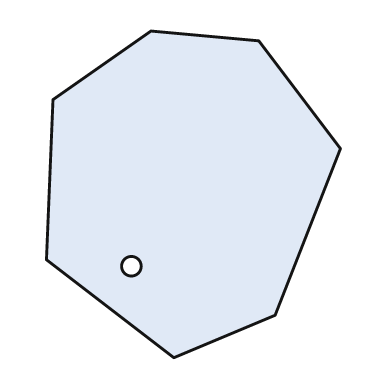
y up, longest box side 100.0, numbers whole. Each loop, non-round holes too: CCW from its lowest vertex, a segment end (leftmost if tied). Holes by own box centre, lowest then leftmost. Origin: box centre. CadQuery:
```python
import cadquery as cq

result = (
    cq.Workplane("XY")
    .moveTo(-6.0, -50.0)
    .lineTo(25.0, -37.0)
    .lineTo(45.0, 14.0)
    .lineTo(20.0, 47.0)
    .lineTo(-13.0, 50.0)
    .lineTo(-43.0, 29.0)
    .lineTo(-45.0, -20.0)
    .close()
    .moveTo(-19.0, -22.0)
    .circle(3.0)
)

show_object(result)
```